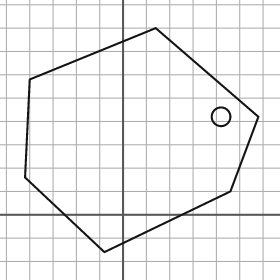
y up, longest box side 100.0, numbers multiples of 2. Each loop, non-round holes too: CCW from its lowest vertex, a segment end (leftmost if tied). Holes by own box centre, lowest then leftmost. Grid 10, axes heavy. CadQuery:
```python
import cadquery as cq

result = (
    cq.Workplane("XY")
    .moveTo(-8.0, -16.0)
    .lineTo(46.0, 10.0)
    .lineTo(58.0, 42.0)
    .lineTo(14.0, 80.0)
    .lineTo(-40.0, 58.0)
    .lineTo(-42.0, 16.0)
    .close()
    .moveTo(42.0, 42.0)
    .circle(4.0)
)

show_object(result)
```